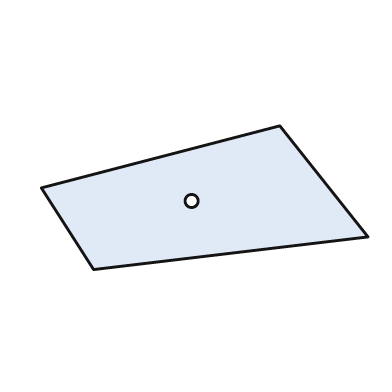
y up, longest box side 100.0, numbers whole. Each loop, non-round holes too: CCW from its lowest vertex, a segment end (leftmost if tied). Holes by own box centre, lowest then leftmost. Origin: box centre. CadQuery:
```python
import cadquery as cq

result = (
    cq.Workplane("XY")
    .moveTo(-34.0, -22.0)
    .lineTo(50.0, -12.0)
    .lineTo(23.0, 22.0)
    .lineTo(-50.0, 3.0)
    .close()
    .moveTo(-4.0, -1.0)
    .circle(2.0)
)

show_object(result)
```